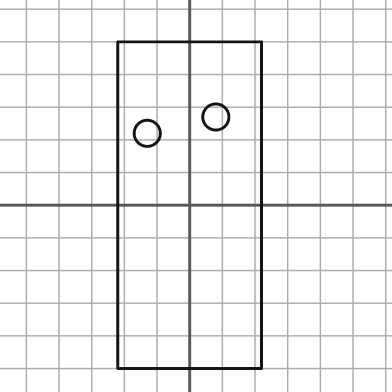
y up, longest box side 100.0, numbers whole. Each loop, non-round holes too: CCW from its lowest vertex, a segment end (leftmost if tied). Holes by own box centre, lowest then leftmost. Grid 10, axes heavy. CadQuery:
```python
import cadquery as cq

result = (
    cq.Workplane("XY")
    .moveTo(-22.0, -50.0)
    .lineTo(22.0, -50.0)
    .lineTo(22.0, 50.0)
    .lineTo(-22.0, 50.0)
    .close()
    .moveTo(-13.0, 22.0)
    .circle(4.0)
    .moveTo(8.0, 27.0)
    .circle(4.0)
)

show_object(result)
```